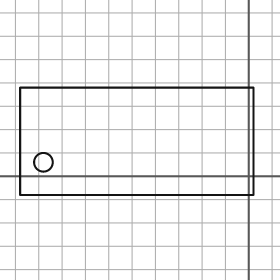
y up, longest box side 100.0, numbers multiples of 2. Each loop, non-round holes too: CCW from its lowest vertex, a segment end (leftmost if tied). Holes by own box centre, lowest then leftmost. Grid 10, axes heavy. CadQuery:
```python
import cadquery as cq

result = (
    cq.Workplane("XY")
    .moveTo(-98.0, -8.0)
    .lineTo(2.0, -8.0)
    .lineTo(2.0, 38.0)
    .lineTo(-98.0, 38.0)
    .close()
    .moveTo(-88.0, 6.0)
    .circle(4.0)
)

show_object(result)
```